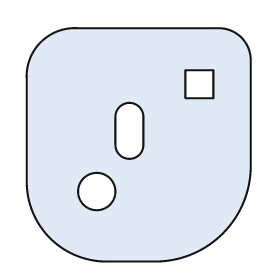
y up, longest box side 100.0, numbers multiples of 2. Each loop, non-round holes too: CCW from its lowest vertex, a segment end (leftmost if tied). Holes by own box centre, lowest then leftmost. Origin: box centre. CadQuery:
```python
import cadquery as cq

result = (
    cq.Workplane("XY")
    .moveTo(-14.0, -50.0)
    .lineTo(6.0, -50.0)
    .threePointArc((36.0, -38.0), (48.0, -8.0))
    .lineTo(48.0, 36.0)
    .threePointArc((44.0, 46.0), (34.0, 50.0))
    .lineTo(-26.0, 50.0)
    .threePointArc((-42.0, 44.0), (-48.0, 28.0))
    .lineTo(-48.0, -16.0)
    .threePointArc((-38.0, -40.0), (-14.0, -50.0))
    .close()
    .moveTo(-18.0, -20.0)
    .circle(8.0)
    .moveTo(-10.0, 0.0)
    .threePointArc((-4.0, -6.0), (2.0, 0.0))
    .lineTo(2.0, 12.0)
    .threePointArc((-4.0, 18.0), (-10.0, 12.0))
    .close()
    .moveTo(20.0, 20.0)
    .lineTo(32.0, 20.0)
    .lineTo(32.0, 32.0)
    .lineTo(20.0, 32.0)
    .close()
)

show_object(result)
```